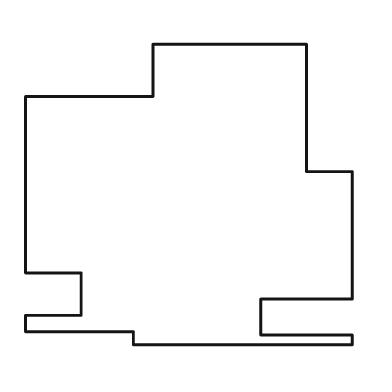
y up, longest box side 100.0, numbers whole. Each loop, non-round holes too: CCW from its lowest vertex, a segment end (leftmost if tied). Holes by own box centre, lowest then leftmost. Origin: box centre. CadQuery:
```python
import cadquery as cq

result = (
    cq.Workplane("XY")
    .moveTo(-17.0, -46.0)
    .lineTo(50.0, -46.0)
    .lineTo(50.0, -43.0)
    .lineTo(22.0, -43.0)
    .lineTo(22.0, -32.0)
    .lineTo(50.0, -32.0)
    .lineTo(50.0, 7.0)
    .lineTo(36.0, 7.0)
    .lineTo(36.0, 46.0)
    .lineTo(-11.0, 46.0)
    .lineTo(-11.0, 30.0)
    .lineTo(-50.0, 30.0)
    .lineTo(-50.0, -24.0)
    .lineTo(-33.0, -24.0)
    .lineTo(-33.0, -37.0)
    .lineTo(-50.0, -37.0)
    .lineTo(-50.0, -42.0)
    .lineTo(-17.0, -42.0)
    .close()
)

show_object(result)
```